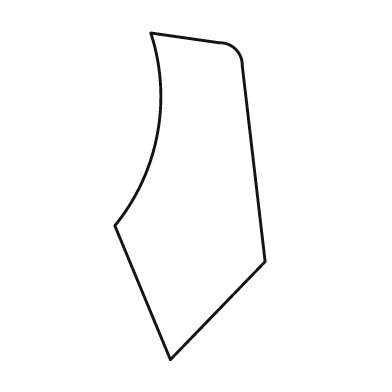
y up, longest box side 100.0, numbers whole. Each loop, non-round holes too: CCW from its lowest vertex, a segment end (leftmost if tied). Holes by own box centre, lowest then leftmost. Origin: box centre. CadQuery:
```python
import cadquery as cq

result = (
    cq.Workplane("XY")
    .moveTo(-6.0, -50.0)
    .lineTo(23.0, -20.0)
    .lineTo(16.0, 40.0)
    .threePointArc((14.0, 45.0), (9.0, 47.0))
    .lineTo(-12.0, 50.0)
    .threePointArc((-10.0, 19.0), (-23.0, -9.0))
    .close()
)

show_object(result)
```